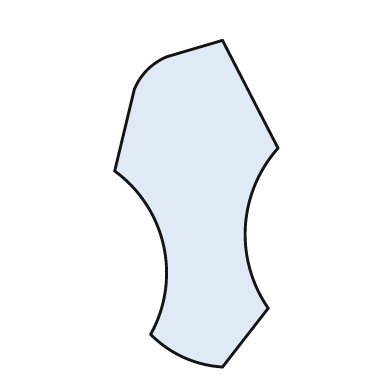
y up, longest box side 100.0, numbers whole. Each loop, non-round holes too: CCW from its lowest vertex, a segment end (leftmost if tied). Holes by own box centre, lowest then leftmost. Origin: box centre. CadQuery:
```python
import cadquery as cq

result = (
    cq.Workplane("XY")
    .moveTo(8.0, -50.0)
    .lineTo(22.0, -32.0)
    .threePointArc((15.0, -7.0), (25.0, 17.0))
    .lineTo(8.0, 50.0)
    .lineTo(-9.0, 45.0)
    .threePointArc((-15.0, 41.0), (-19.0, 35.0))
    .lineTo(-25.0, 10.0)
    .threePointArc((-10.0, -13.0), (-14.0, -40.0))
    .threePointArc((-4.0, -47.0), (8.0, -50.0))
    .close()
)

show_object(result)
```